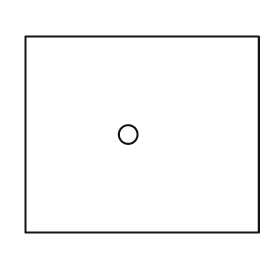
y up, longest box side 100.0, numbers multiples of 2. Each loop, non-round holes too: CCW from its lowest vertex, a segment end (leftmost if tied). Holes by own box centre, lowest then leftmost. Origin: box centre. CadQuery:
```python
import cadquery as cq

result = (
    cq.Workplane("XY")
    .moveTo(-50.0, -42.0)
    .lineTo(50.0, -42.0)
    .lineTo(50.0, 42.0)
    .lineTo(-50.0, 42.0)
    .close()
    .moveTo(-6.0, 0.0)
    .circle(4.0)
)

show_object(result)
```